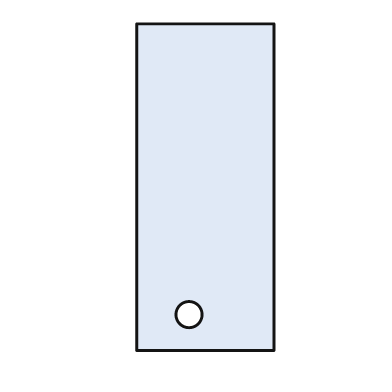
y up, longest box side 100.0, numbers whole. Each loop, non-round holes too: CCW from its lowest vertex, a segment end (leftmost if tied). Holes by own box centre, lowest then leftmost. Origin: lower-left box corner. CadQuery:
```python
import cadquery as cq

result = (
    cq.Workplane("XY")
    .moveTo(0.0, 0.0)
    .lineTo(42.0, 0.0)
    .lineTo(42.0, 100.0)
    .lineTo(0.0, 100.0)
    .close()
    .moveTo(16.0, 11.0)
    .circle(4.0)
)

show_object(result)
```